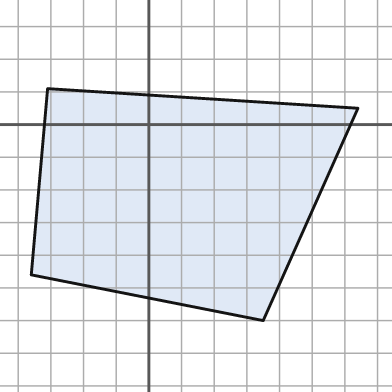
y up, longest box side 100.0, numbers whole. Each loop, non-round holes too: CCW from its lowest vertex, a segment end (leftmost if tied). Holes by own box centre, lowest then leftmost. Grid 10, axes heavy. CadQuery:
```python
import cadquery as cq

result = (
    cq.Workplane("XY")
    .moveTo(35.0, -60.0)
    .lineTo(64.0, 5.0)
    .lineTo(-31.0, 11.0)
    .lineTo(-36.0, -46.0)
    .close()
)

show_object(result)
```